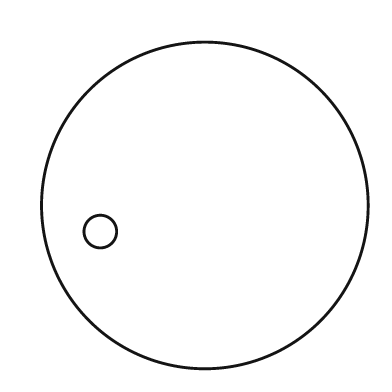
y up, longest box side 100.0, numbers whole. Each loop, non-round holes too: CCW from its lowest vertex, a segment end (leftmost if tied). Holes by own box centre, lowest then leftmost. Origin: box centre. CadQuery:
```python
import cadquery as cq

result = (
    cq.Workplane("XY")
    .moveTo(0.0, 0.0)
    .circle(50.0)
    .moveTo(-32.0, -8.0)
    .circle(5.0)
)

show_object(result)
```